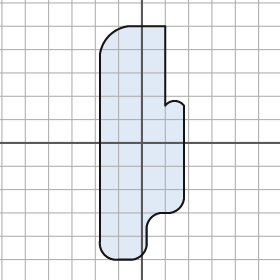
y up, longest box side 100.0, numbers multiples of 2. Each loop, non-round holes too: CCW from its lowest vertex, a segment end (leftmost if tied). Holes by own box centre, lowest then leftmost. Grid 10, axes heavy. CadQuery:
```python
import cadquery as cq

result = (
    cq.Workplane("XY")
    .moveTo(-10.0, -50.0)
    .lineTo(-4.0, -50.0)
    .threePointArc((0.0, -48.0), (2.0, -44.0))
    .lineTo(2.0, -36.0)
    .threePointArc((4.0, -32.0), (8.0, -30.0))
    .lineTo(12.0, -30.0)
    .threePointArc((16.0, -28.0), (18.0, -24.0))
    .lineTo(18.0, 16.0)
    .threePointArc((14.0, 18.0), (10.0, 16.0))
    .lineTo(10.0, 50.0)
    .lineTo(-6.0, 50.0)
    .threePointArc((-14.0, 46.0), (-18.0, 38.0))
    .lineTo(-18.0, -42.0)
    .threePointArc((-16.0, -48.0), (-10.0, -50.0))
    .close()
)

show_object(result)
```